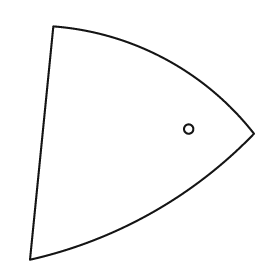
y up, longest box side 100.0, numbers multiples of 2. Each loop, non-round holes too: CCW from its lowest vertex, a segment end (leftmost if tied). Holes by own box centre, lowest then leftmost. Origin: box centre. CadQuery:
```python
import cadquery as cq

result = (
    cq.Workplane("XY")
    .moveTo(-48.0, -50.0)
    .threePointArc((4.0, -30.0), (48.0, 4.0))
    .threePointArc((10.0, 36.0), (-38.0, 50.0))
    .close()
    .moveTo(20.0, 6.0)
    .circle(2.0)
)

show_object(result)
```